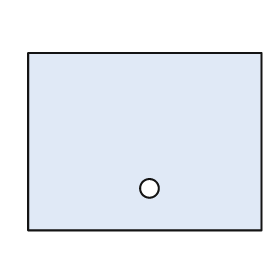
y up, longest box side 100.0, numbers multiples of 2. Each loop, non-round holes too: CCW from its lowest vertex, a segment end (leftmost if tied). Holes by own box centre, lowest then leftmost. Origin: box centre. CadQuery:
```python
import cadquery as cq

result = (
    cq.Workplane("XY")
    .moveTo(-50.0, -38.0)
    .lineTo(50.0, -38.0)
    .lineTo(50.0, 38.0)
    .lineTo(-50.0, 38.0)
    .close()
    .moveTo(2.0, -20.0)
    .circle(4.0)
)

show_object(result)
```